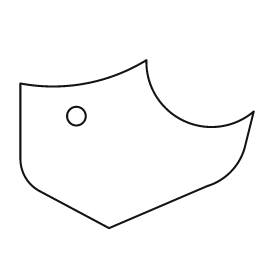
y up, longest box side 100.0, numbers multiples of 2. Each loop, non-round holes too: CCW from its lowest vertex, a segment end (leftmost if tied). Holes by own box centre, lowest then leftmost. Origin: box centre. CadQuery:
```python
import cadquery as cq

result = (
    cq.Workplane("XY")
    .moveTo(-12.0, -36.0)
    .lineTo(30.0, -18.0)
    .threePointArc((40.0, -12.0), (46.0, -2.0))
    .lineTo(50.0, 14.0)
    .threePointArc((20.0, 10.0), (4.0, 36.0))
    .threePointArc((-22.0, 26.0), (-50.0, 26.0))
    .lineTo(-50.0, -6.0)
    .threePointArc((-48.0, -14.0), (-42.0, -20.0))
    .close()
    .moveTo(-26.0, 12.0)
    .circle(4.0)
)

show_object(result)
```